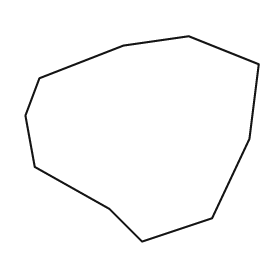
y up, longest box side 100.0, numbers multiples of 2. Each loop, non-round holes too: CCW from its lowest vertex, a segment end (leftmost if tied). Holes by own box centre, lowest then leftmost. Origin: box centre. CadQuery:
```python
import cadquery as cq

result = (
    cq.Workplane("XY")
    .moveTo(0.0, -44.0)
    .lineTo(30.0, -34.0)
    .lineTo(46.0, 0.0)
    .lineTo(50.0, 32.0)
    .lineTo(20.0, 44.0)
    .lineTo(-8.0, 40.0)
    .lineTo(-44.0, 26.0)
    .lineTo(-50.0, 10.0)
    .lineTo(-46.0, -12.0)
    .lineTo(-14.0, -30.0)
    .close()
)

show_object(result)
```